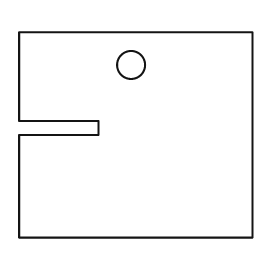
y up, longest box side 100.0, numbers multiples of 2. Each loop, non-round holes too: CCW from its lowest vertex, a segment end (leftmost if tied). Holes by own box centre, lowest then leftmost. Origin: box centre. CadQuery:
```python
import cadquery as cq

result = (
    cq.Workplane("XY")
    .moveTo(-50.0, -44.0)
    .lineTo(50.0, -44.0)
    .lineTo(50.0, 44.0)
    .lineTo(-50.0, 44.0)
    .lineTo(-50.0, 6.0)
    .lineTo(-16.0, 6.0)
    .lineTo(-16.0, 0.0)
    .lineTo(-50.0, 0.0)
    .close()
    .moveTo(-2.0, 30.0)
    .circle(6.0)
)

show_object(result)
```